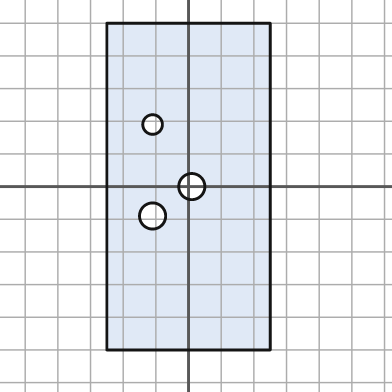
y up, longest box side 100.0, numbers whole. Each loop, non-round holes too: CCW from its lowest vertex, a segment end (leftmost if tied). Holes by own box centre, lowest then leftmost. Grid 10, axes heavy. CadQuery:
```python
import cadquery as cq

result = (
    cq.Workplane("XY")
    .moveTo(-25.0, -50.0)
    .lineTo(25.0, -50.0)
    .lineTo(25.0, 50.0)
    .lineTo(-25.0, 50.0)
    .close()
    .moveTo(-11.0, -9.0)
    .circle(4.0)
    .moveTo(1.0, 0.0)
    .circle(4.0)
    .moveTo(-11.0, 19.0)
    .circle(3.0)
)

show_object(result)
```